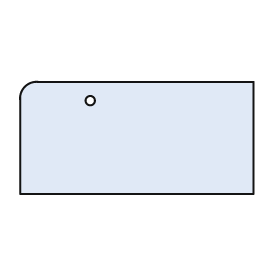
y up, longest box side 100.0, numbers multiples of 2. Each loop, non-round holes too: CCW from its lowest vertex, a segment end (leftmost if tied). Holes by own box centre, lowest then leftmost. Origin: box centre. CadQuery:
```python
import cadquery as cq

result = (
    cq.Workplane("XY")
    .moveTo(-50.0, -24.0)
    .lineTo(50.0, -24.0)
    .lineTo(50.0, 24.0)
    .lineTo(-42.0, 24.0)
    .threePointArc((-48.0, 22.0), (-50.0, 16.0))
    .close()
    .moveTo(-20.0, 16.0)
    .circle(2.0)
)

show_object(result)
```